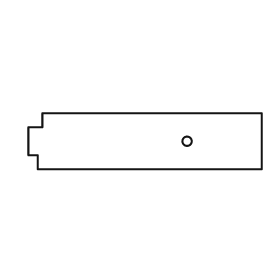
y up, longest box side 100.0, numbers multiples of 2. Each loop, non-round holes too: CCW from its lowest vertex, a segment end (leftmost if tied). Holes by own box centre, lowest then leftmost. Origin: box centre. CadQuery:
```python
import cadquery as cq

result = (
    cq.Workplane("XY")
    .moveTo(-46.0, -12.0)
    .lineTo(50.0, -12.0)
    .lineTo(50.0, 12.0)
    .lineTo(-44.0, 12.0)
    .lineTo(-44.0, 6.0)
    .lineTo(-50.0, 6.0)
    .lineTo(-50.0, -6.0)
    .lineTo(-46.0, -6.0)
    .close()
    .moveTo(18.0, 0.0)
    .circle(2.0)
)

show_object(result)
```